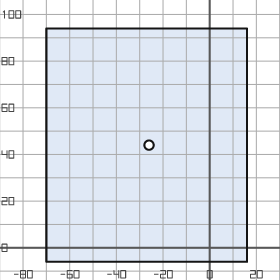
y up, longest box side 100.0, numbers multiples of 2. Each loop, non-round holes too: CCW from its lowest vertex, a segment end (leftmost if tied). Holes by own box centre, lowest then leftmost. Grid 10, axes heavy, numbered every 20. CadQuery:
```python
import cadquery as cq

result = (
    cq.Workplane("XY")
    .moveTo(-70.0, -6.0)
    .lineTo(16.0, -6.0)
    .lineTo(16.0, 94.0)
    .lineTo(-70.0, 94.0)
    .close()
    .moveTo(-26.0, 44.0)
    .circle(2.0)
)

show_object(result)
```